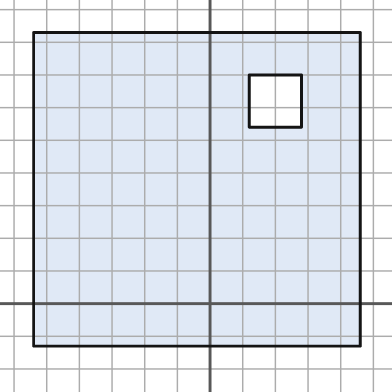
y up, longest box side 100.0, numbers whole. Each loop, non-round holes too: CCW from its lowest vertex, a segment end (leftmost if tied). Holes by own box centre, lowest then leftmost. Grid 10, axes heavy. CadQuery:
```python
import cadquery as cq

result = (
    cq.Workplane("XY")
    .moveTo(-54.0, -13.0)
    .lineTo(46.0, -13.0)
    .lineTo(46.0, 83.0)
    .lineTo(-54.0, 83.0)
    .close()
    .moveTo(12.0, 54.0)
    .lineTo(28.0, 54.0)
    .lineTo(28.0, 70.0)
    .lineTo(12.0, 70.0)
    .close()
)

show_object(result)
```